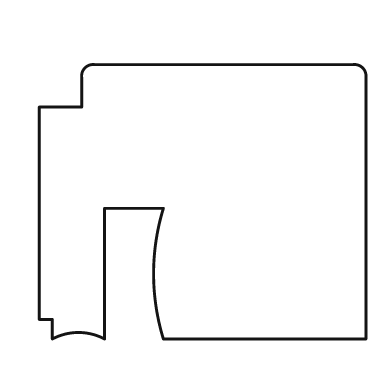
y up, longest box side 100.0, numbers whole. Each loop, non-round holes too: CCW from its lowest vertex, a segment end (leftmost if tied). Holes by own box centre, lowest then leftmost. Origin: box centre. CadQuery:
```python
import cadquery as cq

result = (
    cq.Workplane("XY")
    .moveTo(-46.0, -42.0)
    .threePointArc((-38.0, -40.0), (-30.0, -42.0))
    .lineTo(-30.0, -2.0)
    .lineTo(-12.0, -2.0)
    .threePointArc((-15.0, -22.0), (-12.0, -42.0))
    .lineTo(50.0, -42.0)
    .lineTo(50.0, 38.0)
    .threePointArc((49.0, 41.0), (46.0, 42.0))
    .lineTo(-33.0, 42.0)
    .threePointArc((-36.0, 41.0), (-37.0, 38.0))
    .lineTo(-37.0, 29.0)
    .lineTo(-50.0, 29.0)
    .lineTo(-50.0, -36.0)
    .lineTo(-46.0, -36.0)
    .close()
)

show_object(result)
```